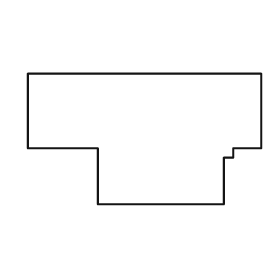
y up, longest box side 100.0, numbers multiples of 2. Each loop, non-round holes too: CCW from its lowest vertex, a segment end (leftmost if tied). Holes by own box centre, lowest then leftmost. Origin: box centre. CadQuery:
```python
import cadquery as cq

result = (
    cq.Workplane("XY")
    .moveTo(-20.0, -28.0)
    .lineTo(34.0, -28.0)
    .lineTo(34.0, -8.0)
    .lineTo(38.0, -8.0)
    .lineTo(38.0, -4.0)
    .lineTo(50.0, -4.0)
    .lineTo(50.0, 28.0)
    .lineTo(-50.0, 28.0)
    .lineTo(-50.0, -4.0)
    .lineTo(-20.0, -4.0)
    .close()
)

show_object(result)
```